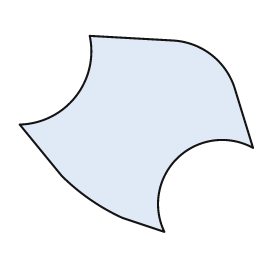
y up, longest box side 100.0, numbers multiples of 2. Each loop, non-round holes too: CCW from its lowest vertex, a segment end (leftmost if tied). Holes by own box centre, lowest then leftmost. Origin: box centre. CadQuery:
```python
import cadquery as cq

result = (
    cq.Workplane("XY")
    .moveTo(12.0, -42.0)
    .threePointArc((18.0, -10.0), (50.0, -6.0))
    .lineTo(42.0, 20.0)
    .threePointArc((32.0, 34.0), (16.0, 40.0))
    .lineTo(-20.0, 42.0)
    .threePointArc((-26.0, 16.0), (-50.0, 4.0))
    .lineTo(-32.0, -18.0)
    .threePointArc((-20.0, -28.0), (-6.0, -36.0))
    .close()
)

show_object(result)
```